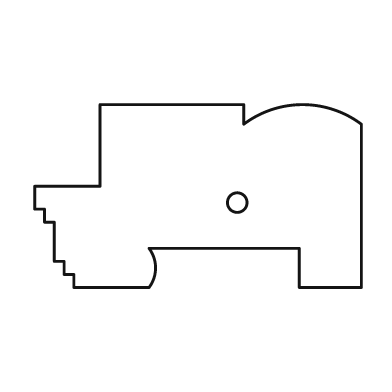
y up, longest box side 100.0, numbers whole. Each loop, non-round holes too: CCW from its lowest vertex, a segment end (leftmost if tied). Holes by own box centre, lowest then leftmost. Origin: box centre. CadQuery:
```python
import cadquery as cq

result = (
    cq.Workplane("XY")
    .moveTo(-38.0, -28.0)
    .lineTo(-15.0, -28.0)
    .threePointArc((-13.0, -22.0), (-15.0, -16.0))
    .lineTo(31.0, -16.0)
    .lineTo(31.0, -28.0)
    .lineTo(50.0, -28.0)
    .lineTo(50.0, 22.0)
    .threePointArc((32.0, 28.0), (14.0, 22.0))
    .lineTo(14.0, 28.0)
    .lineTo(-30.0, 28.0)
    .lineTo(-30.0, 3.0)
    .lineTo(-50.0, 3.0)
    .lineTo(-50.0, -4.0)
    .lineTo(-47.0, -4.0)
    .lineTo(-47.0, -8.0)
    .lineTo(-44.0, -8.0)
    .lineTo(-44.0, -20.0)
    .lineTo(-41.0, -20.0)
    .lineTo(-41.0, -24.0)
    .lineTo(-38.0, -24.0)
    .close()
    .moveTo(12.0, -2.0)
    .circle(3.0)
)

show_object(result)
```